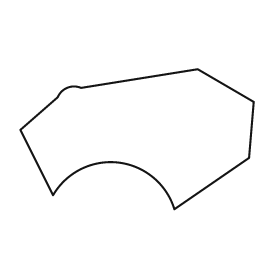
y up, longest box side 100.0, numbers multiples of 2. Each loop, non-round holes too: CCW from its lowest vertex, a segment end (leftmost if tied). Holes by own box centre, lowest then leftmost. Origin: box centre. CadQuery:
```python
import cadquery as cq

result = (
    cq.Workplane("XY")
    .moveTo(16.0, -30.0)
    .lineTo(48.0, -8.0)
    .lineTo(50.0, 16.0)
    .lineTo(26.0, 30.0)
    .lineTo(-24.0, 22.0)
    .threePointArc((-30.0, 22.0), (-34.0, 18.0))
    .lineTo(-50.0, 4.0)
    .lineTo(-36.0, -24.0)
    .threePointArc((-8.0, -10.0), (16.0, -30.0))
    .close()
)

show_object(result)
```